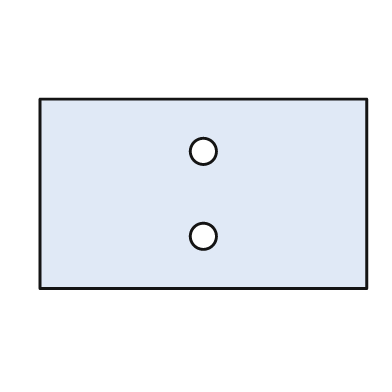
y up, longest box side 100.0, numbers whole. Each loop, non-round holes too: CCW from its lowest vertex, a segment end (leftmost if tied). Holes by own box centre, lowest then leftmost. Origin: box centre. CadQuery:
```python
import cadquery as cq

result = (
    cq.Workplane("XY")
    .moveTo(-50.0, -29.0)
    .lineTo(50.0, -29.0)
    .lineTo(50.0, 29.0)
    .lineTo(-50.0, 29.0)
    .close()
    .moveTo(0.0, -13.0)
    .circle(4.0)
    .moveTo(0.0, 13.0)
    .circle(4.0)
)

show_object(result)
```